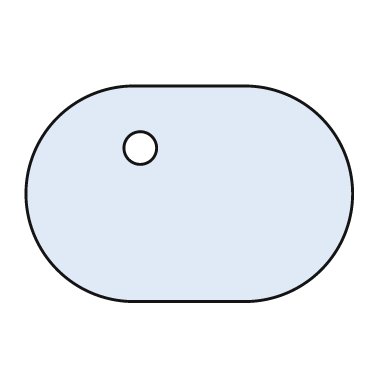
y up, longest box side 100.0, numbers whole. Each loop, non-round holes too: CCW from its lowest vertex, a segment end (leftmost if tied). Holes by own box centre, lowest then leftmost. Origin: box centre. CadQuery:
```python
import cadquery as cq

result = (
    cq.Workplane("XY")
    .moveTo(-17.0, -33.0)
    .lineTo(17.0, -33.0)
    .threePointArc((50.0, 0.0), (17.0, 33.0))
    .lineTo(-17.0, 33.0)
    .threePointArc((-50.0, 0.0), (-17.0, -33.0))
    .close()
    .moveTo(-15.0, 14.0)
    .circle(5.0)
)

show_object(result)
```